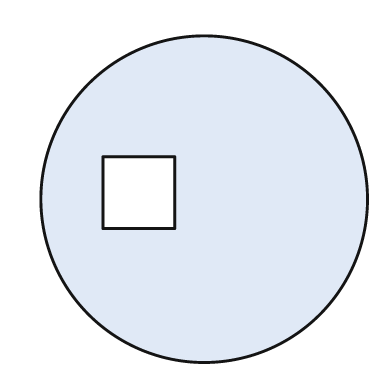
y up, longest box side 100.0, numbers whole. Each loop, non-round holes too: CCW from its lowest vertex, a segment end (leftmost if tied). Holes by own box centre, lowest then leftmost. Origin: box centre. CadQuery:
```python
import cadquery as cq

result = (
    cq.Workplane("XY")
    .moveTo(0.0, 0.0)
    .circle(50.0)
    .moveTo(-31.0, -9.0)
    .lineTo(-9.0, -9.0)
    .lineTo(-9.0, 13.0)
    .lineTo(-31.0, 13.0)
    .close()
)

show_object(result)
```